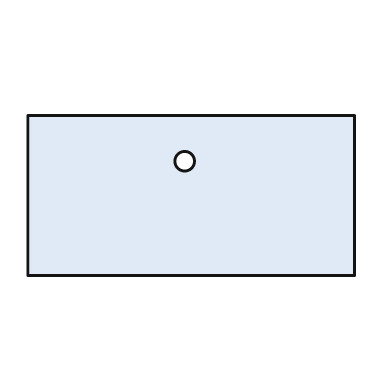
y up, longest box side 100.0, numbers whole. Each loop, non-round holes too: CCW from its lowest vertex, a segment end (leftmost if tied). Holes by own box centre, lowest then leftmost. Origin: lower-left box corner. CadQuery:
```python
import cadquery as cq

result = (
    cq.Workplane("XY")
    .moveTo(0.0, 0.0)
    .lineTo(100.0, 0.0)
    .lineTo(100.0, 49.0)
    .lineTo(0.0, 49.0)
    .close()
    .moveTo(48.0, 35.0)
    .circle(3.0)
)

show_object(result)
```